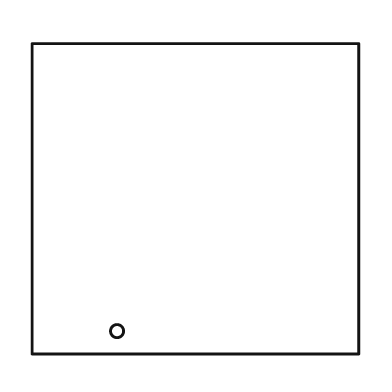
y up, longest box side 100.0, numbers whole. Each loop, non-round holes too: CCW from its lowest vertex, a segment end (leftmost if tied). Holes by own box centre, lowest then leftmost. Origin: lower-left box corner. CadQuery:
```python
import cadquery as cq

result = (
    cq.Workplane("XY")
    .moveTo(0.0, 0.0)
    .lineTo(100.0, 0.0)
    .lineTo(100.0, 95.0)
    .lineTo(0.0, 95.0)
    .close()
    .moveTo(26.0, 7.0)
    .circle(2.0)
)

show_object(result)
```